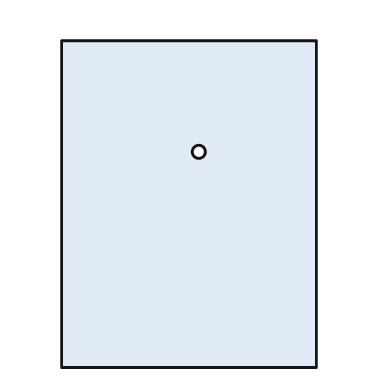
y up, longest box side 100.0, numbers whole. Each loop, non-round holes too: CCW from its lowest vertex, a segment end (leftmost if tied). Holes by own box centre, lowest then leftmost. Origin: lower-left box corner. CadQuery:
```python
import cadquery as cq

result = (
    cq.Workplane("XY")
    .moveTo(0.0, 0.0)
    .lineTo(78.0, 0.0)
    .lineTo(78.0, 100.0)
    .lineTo(0.0, 100.0)
    .close()
    .moveTo(42.0, 66.0)
    .circle(2.0)
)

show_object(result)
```